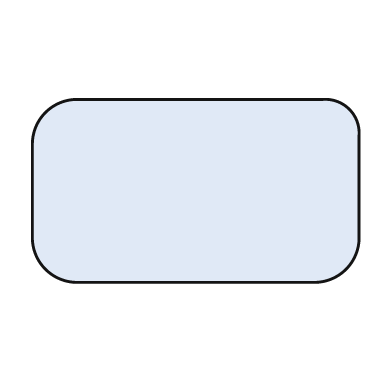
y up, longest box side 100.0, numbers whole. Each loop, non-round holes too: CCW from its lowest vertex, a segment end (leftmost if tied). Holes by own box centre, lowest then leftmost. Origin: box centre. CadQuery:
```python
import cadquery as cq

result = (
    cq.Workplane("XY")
    .moveTo(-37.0, -28.0)
    .lineTo(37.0, -28.0)
    .threePointArc((46.0, -24.0), (50.0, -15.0))
    .lineTo(50.0, 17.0)
    .threePointArc((47.0, 25.0), (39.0, 28.0))
    .lineTo(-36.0, 28.0)
    .threePointArc((-46.0, 24.0), (-50.0, 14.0))
    .lineTo(-50.0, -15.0)
    .threePointArc((-46.0, -24.0), (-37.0, -28.0))
    .close()
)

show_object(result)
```